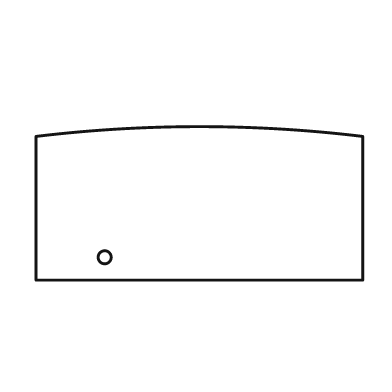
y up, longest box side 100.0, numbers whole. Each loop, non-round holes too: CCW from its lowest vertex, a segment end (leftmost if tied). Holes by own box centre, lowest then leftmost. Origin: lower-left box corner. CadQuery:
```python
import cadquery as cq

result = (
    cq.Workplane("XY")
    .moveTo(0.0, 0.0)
    .lineTo(100.0, 0.0)
    .lineTo(100.0, 44.0)
    .threePointArc((50.0, 47.0), (0.0, 44.0))
    .close()
    .moveTo(21.0, 7.0)
    .circle(2.0)
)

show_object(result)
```